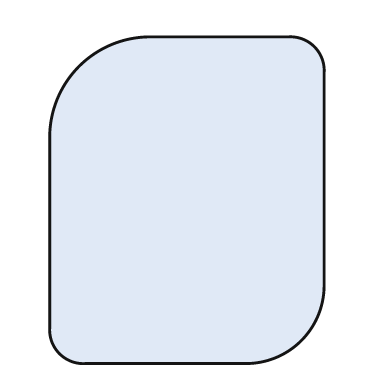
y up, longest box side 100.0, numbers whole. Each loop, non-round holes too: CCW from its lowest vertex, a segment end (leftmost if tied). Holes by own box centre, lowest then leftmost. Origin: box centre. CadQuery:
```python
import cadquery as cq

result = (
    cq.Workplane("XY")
    .moveTo(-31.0, -50.0)
    .lineTo(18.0, -50.0)
    .threePointArc((35.0, -43.0), (42.0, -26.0))
    .lineTo(42.0, 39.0)
    .threePointArc((39.0, 47.0), (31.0, 50.0))
    .lineTo(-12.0, 50.0)
    .threePointArc((-33.0, 41.0), (-42.0, 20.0))
    .lineTo(-42.0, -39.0)
    .threePointArc((-39.0, -47.0), (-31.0, -50.0))
    .close()
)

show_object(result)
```